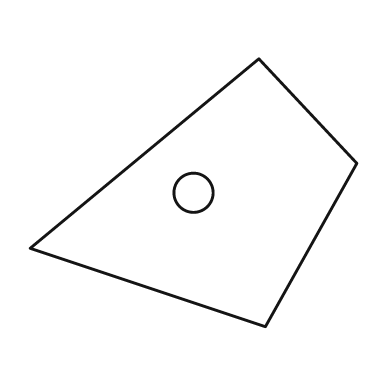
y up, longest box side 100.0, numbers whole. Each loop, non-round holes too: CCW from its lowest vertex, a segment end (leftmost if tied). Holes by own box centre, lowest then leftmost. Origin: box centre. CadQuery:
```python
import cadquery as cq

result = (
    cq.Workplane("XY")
    .moveTo(22.0, -41.0)
    .lineTo(50.0, 9.0)
    .lineTo(20.0, 41.0)
    .lineTo(-50.0, -17.0)
    .close()
    .moveTo(0.0, 0.0)
    .circle(6.0)
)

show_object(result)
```